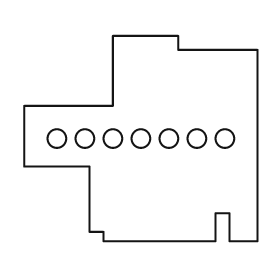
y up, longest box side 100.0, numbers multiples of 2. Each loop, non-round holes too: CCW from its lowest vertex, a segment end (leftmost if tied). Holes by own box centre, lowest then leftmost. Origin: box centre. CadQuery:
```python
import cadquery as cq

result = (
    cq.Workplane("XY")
    .moveTo(-16.0, -44.0)
    .lineTo(32.0, -44.0)
    .lineTo(32.0, -32.0)
    .lineTo(38.0, -32.0)
    .lineTo(38.0, -44.0)
    .lineTo(50.0, -44.0)
    .lineTo(50.0, 38.0)
    .lineTo(16.0, 38.0)
    .lineTo(16.0, 44.0)
    .lineTo(-12.0, 44.0)
    .lineTo(-12.0, 14.0)
    .lineTo(-50.0, 14.0)
    .lineTo(-50.0, -12.0)
    .lineTo(-22.0, -12.0)
    .lineTo(-22.0, -40.0)
    .lineTo(-16.0, -40.0)
    .close()
    .moveTo(-36.0, 0.0)
    .circle(4.0)
    .moveTo(-24.0, 0.0)
    .circle(4.0)
    .moveTo(-12.0, 0.0)
    .circle(4.0)
    .moveTo(0.0, 0.0)
    .circle(4.0)
    .moveTo(12.0, 0.0)
    .circle(4.0)
    .moveTo(24.0, 0.0)
    .circle(4.0)
    .moveTo(36.0, 0.0)
    .circle(4.0)
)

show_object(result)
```